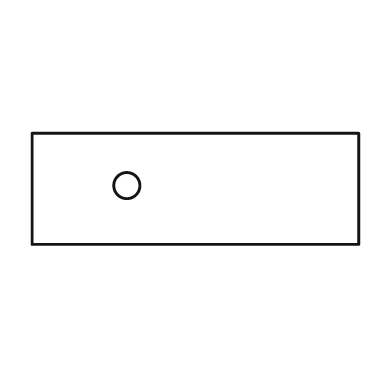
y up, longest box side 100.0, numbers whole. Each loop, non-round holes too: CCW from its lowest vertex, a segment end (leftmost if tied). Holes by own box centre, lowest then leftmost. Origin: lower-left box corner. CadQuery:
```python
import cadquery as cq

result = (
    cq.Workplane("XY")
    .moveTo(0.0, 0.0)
    .lineTo(100.0, 0.0)
    .lineTo(100.0, 34.0)
    .lineTo(0.0, 34.0)
    .close()
    .moveTo(29.0, 18.0)
    .circle(4.0)
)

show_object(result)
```